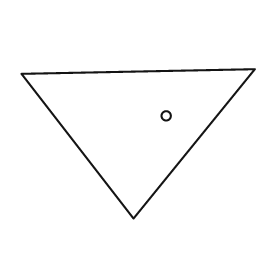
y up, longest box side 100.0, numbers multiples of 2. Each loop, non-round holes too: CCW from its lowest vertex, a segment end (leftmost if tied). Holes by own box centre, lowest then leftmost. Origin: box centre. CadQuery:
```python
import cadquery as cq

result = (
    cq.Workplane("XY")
    .moveTo(-2.0, -32.0)
    .lineTo(50.0, 32.0)
    .lineTo(-50.0, 30.0)
    .close()
    .moveTo(12.0, 12.0)
    .circle(2.0)
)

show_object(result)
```